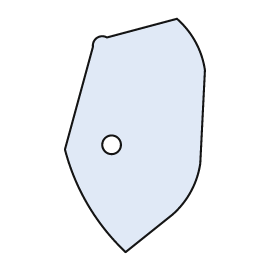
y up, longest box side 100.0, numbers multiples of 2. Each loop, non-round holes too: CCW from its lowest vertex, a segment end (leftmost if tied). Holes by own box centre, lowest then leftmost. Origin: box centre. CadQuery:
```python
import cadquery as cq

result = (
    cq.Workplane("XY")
    .moveTo(-4.0, -50.0)
    .lineTo(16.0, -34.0)
    .threePointArc((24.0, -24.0), (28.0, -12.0))
    .lineTo(30.0, 28.0)
    .threePointArc((26.0, 40.0), (18.0, 50.0))
    .lineTo(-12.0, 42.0)
    .threePointArc((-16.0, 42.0), (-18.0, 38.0))
    .lineTo(-30.0, -6.0)
    .threePointArc((-20.0, -30.0), (-4.0, -50.0))
    .close()
    .moveTo(-10.0, -4.0)
    .circle(4.0)
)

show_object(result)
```